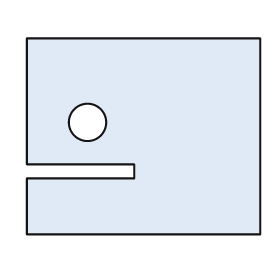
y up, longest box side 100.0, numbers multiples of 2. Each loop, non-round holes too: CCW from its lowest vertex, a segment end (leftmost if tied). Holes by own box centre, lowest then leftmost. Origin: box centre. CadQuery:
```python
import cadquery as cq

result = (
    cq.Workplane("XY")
    .moveTo(-50.0, -42.0)
    .lineTo(50.0, -42.0)
    .lineTo(50.0, 42.0)
    .lineTo(-50.0, 42.0)
    .lineTo(-50.0, -12.0)
    .lineTo(-4.0, -12.0)
    .lineTo(-4.0, -18.0)
    .lineTo(-50.0, -18.0)
    .close()
    .moveTo(-24.0, 6.0)
    .circle(8.0)
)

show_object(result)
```